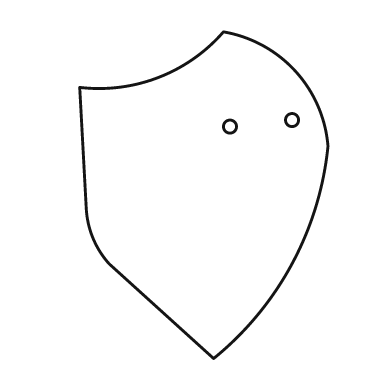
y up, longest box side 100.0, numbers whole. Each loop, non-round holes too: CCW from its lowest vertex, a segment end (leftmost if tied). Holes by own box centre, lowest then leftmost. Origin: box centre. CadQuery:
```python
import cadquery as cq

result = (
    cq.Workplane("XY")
    .moveTo(3.0, -50.0)
    .threePointArc((27.0, -21.0), (38.0, 15.0))
    .threePointArc((28.0, 38.0), (6.0, 50.0))
    .threePointArc((-14.0, 36.0), (-38.0, 33.0))
    .lineTo(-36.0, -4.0)
    .threePointArc((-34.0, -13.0), (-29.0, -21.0))
    .close()
    .moveTo(8.0, 21.0)
    .circle(2.0)
    .moveTo(27.0, 23.0)
    .circle(2.0)
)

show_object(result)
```